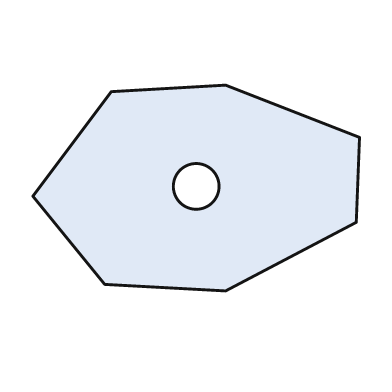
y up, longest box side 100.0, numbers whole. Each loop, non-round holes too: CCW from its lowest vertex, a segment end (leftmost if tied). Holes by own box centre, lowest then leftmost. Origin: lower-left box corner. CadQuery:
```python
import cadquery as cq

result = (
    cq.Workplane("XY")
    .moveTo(59.0, 0.0)
    .lineTo(99.0, 21.0)
    .lineTo(100.0, 47.0)
    .lineTo(59.0, 63.0)
    .lineTo(24.0, 61.0)
    .lineTo(0.0, 29.0)
    .lineTo(22.0, 2.0)
    .close()
    .moveTo(50.0, 32.0)
    .circle(7.0)
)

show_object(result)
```